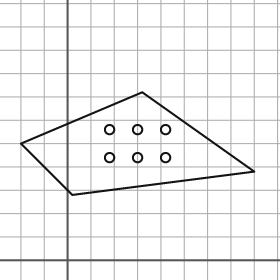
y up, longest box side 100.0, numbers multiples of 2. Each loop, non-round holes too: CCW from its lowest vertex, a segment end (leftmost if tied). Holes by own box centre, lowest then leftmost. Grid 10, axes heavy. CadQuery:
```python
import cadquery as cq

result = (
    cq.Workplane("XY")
    .moveTo(2.0, 28.0)
    .lineTo(80.0, 38.0)
    .lineTo(32.0, 72.0)
    .lineTo(-20.0, 50.0)
    .close()
    .moveTo(18.0, 44.0)
    .circle(2.0)
    .moveTo(30.0, 44.0)
    .circle(2.0)
    .moveTo(42.0, 44.0)
    .circle(2.0)
    .moveTo(18.0, 56.0)
    .circle(2.0)
    .moveTo(30.0, 56.0)
    .circle(2.0)
    .moveTo(42.0, 56.0)
    .circle(2.0)
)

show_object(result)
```